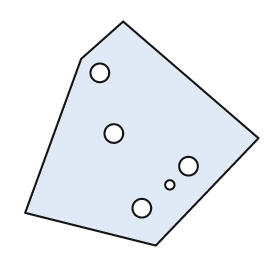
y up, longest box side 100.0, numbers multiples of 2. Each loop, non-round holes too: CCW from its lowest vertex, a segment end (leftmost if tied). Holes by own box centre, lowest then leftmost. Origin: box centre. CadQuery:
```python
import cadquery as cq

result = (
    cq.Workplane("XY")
    .moveTo(6.0, -48.0)
    .lineTo(50.0, -2.0)
    .lineTo(-8.0, 48.0)
    .lineTo(-26.0, 32.0)
    .lineTo(-50.0, -34.0)
    .close()
    .moveTo(0.0, -32.0)
    .circle(4.0)
    .moveTo(12.0, -22.0)
    .circle(2.0)
    .moveTo(20.0, -14.0)
    .circle(4.0)
    .moveTo(-12.0, 0.0)
    .circle(4.0)
    .moveTo(-18.0, 26.0)
    .circle(4.0)
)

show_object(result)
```